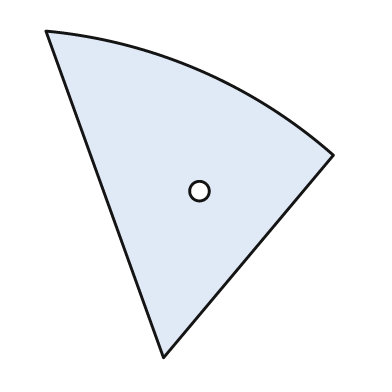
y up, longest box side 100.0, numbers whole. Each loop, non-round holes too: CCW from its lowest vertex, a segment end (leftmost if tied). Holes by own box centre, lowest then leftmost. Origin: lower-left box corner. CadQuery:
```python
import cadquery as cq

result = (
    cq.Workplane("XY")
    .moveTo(36.0, 0.0)
    .lineTo(88.0, 62.0)
    .threePointArc((47.0, 88.0), (0.0, 100.0))
    .close()
    .moveTo(47.0, 51.0)
    .circle(3.0)
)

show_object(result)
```